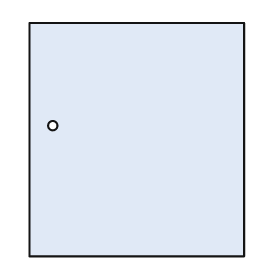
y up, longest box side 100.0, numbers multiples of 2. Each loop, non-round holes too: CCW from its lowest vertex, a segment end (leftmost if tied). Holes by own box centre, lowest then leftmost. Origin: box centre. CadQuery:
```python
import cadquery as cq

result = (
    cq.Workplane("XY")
    .moveTo(-46.0, -50.0)
    .lineTo(46.0, -50.0)
    .lineTo(46.0, 50.0)
    .lineTo(-46.0, 50.0)
    .close()
    .moveTo(-36.0, 6.0)
    .circle(2.0)
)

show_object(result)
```